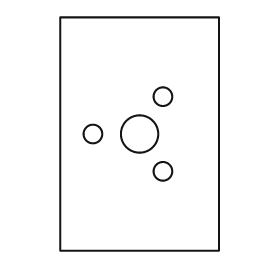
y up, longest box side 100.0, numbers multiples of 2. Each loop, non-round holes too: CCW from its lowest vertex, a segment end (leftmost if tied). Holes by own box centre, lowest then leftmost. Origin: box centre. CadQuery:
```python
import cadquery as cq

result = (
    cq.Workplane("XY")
    .moveTo(-34.0, -50.0)
    .lineTo(34.0, -50.0)
    .lineTo(34.0, 50.0)
    .lineTo(-34.0, 50.0)
    .close()
    .moveTo(10.0, -16.0)
    .circle(4.0)
    .moveTo(-20.0, 0.0)
    .circle(4.0)
    .moveTo(0.0, 0.0)
    .circle(8.0)
    .moveTo(10.0, 16.0)
    .circle(4.0)
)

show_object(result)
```